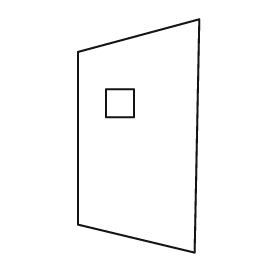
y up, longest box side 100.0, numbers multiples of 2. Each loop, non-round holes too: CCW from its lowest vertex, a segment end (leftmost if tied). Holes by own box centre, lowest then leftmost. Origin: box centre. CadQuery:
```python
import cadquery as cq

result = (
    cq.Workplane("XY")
    .moveTo(24.0, -50.0)
    .lineTo(26.0, 50.0)
    .lineTo(-26.0, 36.0)
    .lineTo(-26.0, -38.0)
    .close()
    .moveTo(-14.0, 8.0)
    .lineTo(-2.0, 8.0)
    .lineTo(-2.0, 20.0)
    .lineTo(-14.0, 20.0)
    .close()
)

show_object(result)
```